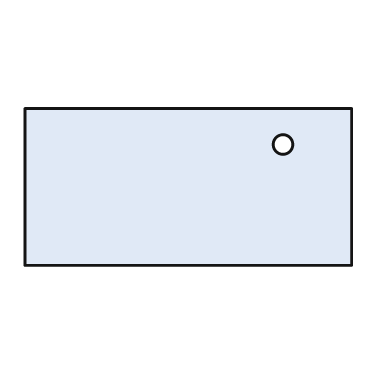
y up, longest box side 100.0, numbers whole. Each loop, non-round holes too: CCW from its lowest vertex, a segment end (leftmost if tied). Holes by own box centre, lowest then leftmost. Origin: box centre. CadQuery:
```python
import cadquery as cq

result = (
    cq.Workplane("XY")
    .moveTo(-50.0, -24.0)
    .lineTo(50.0, -24.0)
    .lineTo(50.0, 24.0)
    .lineTo(-50.0, 24.0)
    .close()
    .moveTo(29.0, 13.0)
    .circle(3.0)
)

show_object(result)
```